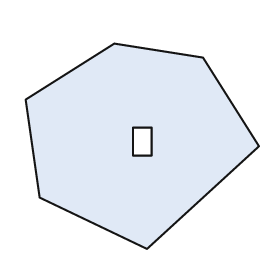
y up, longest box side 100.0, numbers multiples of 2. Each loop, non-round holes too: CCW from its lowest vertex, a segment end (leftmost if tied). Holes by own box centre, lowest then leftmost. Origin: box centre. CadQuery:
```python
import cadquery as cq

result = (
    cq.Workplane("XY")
    .moveTo(2.0, -44.0)
    .lineTo(50.0, 0.0)
    .lineTo(26.0, 38.0)
    .lineTo(-12.0, 44.0)
    .lineTo(-50.0, 20.0)
    .lineTo(-44.0, -22.0)
    .close()
    .moveTo(-4.0, -4.0)
    .lineTo(4.0, -4.0)
    .lineTo(4.0, 8.0)
    .lineTo(-4.0, 8.0)
    .close()
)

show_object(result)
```